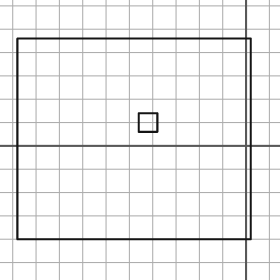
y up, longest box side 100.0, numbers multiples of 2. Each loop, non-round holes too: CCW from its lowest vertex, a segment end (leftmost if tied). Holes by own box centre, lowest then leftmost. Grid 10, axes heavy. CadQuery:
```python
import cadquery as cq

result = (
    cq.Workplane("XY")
    .moveTo(-98.0, -40.0)
    .lineTo(2.0, -40.0)
    .lineTo(2.0, 46.0)
    .lineTo(-98.0, 46.0)
    .close()
    .moveTo(-46.0, 6.0)
    .lineTo(-38.0, 6.0)
    .lineTo(-38.0, 14.0)
    .lineTo(-46.0, 14.0)
    .close()
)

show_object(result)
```